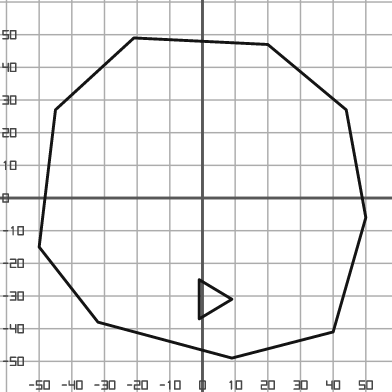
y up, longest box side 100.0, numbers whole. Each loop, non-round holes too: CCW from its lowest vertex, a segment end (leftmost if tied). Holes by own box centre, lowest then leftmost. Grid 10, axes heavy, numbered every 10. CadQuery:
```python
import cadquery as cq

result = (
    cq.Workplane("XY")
    .moveTo(9.0, -49.0)
    .lineTo(40.0, -41.0)
    .lineTo(50.0, -6.0)
    .lineTo(44.0, 27.0)
    .lineTo(20.0, 47.0)
    .lineTo(-21.0, 49.0)
    .lineTo(-45.0, 27.0)
    .lineTo(-50.0, -15.0)
    .lineTo(-32.0, -38.0)
    .close()
    .moveTo(-1.0, -37.0)
    .lineTo(9.0, -31.0)
    .lineTo(-1.0, -25.0)
    .close()
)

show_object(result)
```